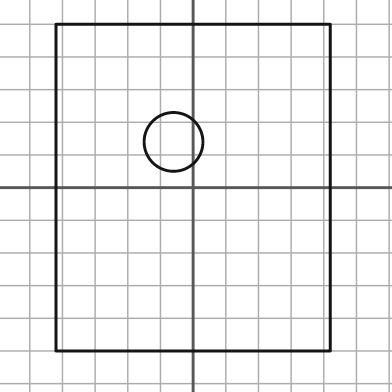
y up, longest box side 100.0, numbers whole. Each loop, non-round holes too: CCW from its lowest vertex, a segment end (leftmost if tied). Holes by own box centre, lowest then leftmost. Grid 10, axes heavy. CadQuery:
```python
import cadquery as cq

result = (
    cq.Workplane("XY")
    .moveTo(-42.0, -50.0)
    .lineTo(42.0, -50.0)
    .lineTo(42.0, 50.0)
    .lineTo(-42.0, 50.0)
    .close()
    .moveTo(-6.0, 14.0)
    .circle(9.0)
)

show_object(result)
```